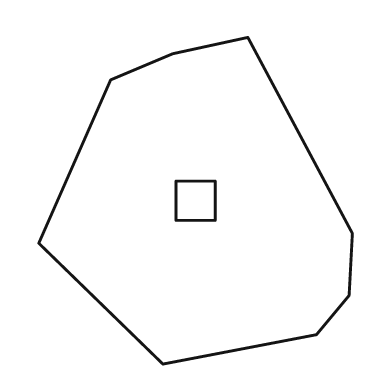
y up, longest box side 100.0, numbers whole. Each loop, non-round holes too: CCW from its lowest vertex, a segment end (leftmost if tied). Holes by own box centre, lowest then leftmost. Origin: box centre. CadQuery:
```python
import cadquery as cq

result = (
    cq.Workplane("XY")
    .moveTo(-10.0, -50.0)
    .lineTo(37.0, -41.0)
    .lineTo(47.0, -29.0)
    .lineTo(48.0, -10.0)
    .lineTo(16.0, 50.0)
    .lineTo(-7.0, 45.0)
    .lineTo(-26.0, 37.0)
    .lineTo(-48.0, -13.0)
    .close()
    .moveTo(-6.0, -6.0)
    .lineTo(6.0, -6.0)
    .lineTo(6.0, 6.0)
    .lineTo(-6.0, 6.0)
    .close()
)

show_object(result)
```